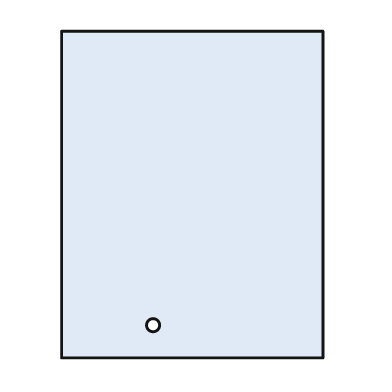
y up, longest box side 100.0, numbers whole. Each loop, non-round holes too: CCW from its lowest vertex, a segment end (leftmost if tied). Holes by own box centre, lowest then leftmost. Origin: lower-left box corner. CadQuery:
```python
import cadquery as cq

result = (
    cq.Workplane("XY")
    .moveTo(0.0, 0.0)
    .lineTo(80.0, 0.0)
    .lineTo(80.0, 100.0)
    .lineTo(0.0, 100.0)
    .close()
    .moveTo(28.0, 10.0)
    .circle(2.0)
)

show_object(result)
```